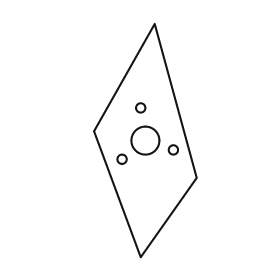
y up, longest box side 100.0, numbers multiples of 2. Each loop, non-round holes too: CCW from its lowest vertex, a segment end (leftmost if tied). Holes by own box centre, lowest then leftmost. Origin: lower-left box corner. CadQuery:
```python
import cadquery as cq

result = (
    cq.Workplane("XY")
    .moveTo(20.0, 0.0)
    .lineTo(44.0, 34.0)
    .lineTo(26.0, 100.0)
    .lineTo(0.0, 54.0)
    .close()
    .moveTo(12.0, 42.0)
    .circle(2.0)
    .moveTo(34.0, 46.0)
    .circle(2.0)
    .moveTo(22.0, 50.0)
    .circle(6.0)
    .moveTo(20.0, 64.0)
    .circle(2.0)
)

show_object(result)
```